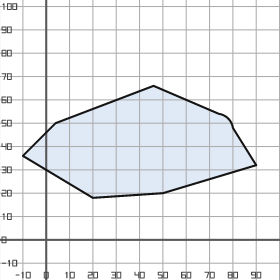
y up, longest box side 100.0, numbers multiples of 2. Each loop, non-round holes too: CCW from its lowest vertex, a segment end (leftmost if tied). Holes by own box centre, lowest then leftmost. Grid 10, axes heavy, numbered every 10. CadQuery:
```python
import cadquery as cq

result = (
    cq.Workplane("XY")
    .moveTo(20.0, 18.0)
    .lineTo(50.0, 20.0)
    .lineTo(90.0, 32.0)
    .lineTo(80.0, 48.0)
    .threePointArc((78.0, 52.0), (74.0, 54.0))
    .lineTo(46.0, 66.0)
    .lineTo(4.0, 50.0)
    .lineTo(-10.0, 36.0)
    .close()
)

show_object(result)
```